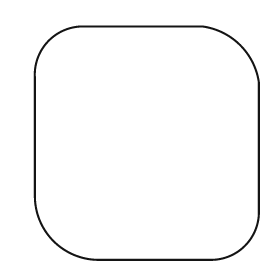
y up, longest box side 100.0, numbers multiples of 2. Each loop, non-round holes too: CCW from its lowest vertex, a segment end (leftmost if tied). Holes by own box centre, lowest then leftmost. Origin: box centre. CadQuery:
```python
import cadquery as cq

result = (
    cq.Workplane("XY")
    .moveTo(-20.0, -50.0)
    .lineTo(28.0, -50.0)
    .threePointArc((42.0, -44.0), (48.0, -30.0))
    .lineTo(48.0, 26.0)
    .threePointArc((40.0, 42.0), (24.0, 50.0))
    .lineTo(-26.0, 50.0)
    .threePointArc((-42.0, 44.0), (-48.0, 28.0))
    .lineTo(-48.0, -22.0)
    .threePointArc((-40.0, -42.0), (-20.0, -50.0))
    .close()
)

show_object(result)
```